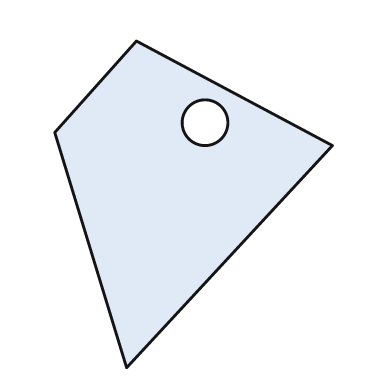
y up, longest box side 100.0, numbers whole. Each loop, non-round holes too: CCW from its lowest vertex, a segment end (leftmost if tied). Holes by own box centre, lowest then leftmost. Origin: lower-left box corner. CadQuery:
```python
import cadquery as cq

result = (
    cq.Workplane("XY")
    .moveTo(22.0, 0.0)
    .lineTo(85.0, 68.0)
    .lineTo(25.0, 100.0)
    .lineTo(0.0, 72.0)
    .close()
    .moveTo(46.0, 75.0)
    .circle(7.0)
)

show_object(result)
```